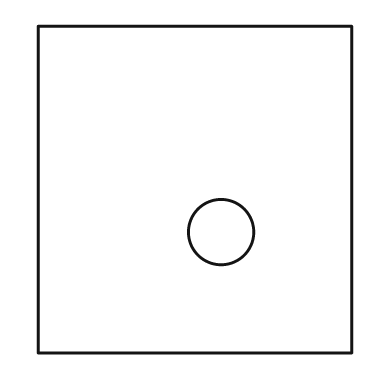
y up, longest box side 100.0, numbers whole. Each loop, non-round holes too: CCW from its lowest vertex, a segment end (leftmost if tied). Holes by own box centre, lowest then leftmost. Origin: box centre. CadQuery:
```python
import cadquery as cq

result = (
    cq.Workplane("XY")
    .moveTo(-48.0, -50.0)
    .lineTo(48.0, -50.0)
    .lineTo(48.0, 50.0)
    .lineTo(-48.0, 50.0)
    .close()
    .moveTo(8.0, -13.0)
    .circle(10.0)
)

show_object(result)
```